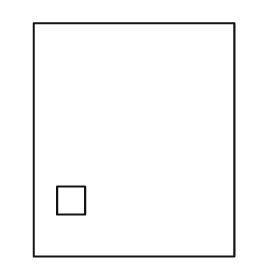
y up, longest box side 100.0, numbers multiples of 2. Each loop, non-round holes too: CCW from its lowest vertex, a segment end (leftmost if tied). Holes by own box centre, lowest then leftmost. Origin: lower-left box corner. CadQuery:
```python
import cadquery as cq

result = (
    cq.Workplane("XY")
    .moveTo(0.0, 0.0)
    .lineTo(86.0, 0.0)
    .lineTo(86.0, 100.0)
    .lineTo(0.0, 100.0)
    .close()
    .moveTo(10.0, 18.0)
    .lineTo(22.0, 18.0)
    .lineTo(22.0, 30.0)
    .lineTo(10.0, 30.0)
    .close()
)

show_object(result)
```